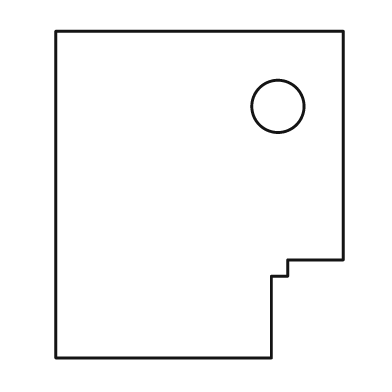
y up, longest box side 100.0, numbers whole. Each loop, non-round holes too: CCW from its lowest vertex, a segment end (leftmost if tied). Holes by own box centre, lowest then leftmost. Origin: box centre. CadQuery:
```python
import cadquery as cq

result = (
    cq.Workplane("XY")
    .moveTo(-44.0, -50.0)
    .lineTo(22.0, -50.0)
    .lineTo(22.0, -25.0)
    .lineTo(27.0, -25.0)
    .lineTo(27.0, -20.0)
    .lineTo(44.0, -20.0)
    .lineTo(44.0, 50.0)
    .lineTo(-44.0, 50.0)
    .close()
    .moveTo(24.0, 27.0)
    .circle(8.0)
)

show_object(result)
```